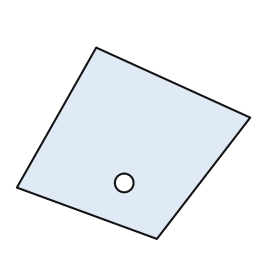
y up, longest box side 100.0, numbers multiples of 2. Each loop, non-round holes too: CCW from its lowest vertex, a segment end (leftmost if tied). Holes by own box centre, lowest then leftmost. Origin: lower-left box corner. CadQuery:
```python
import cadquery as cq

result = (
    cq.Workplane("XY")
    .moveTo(60.0, 0.0)
    .lineTo(100.0, 52.0)
    .lineTo(34.0, 82.0)
    .lineTo(0.0, 22.0)
    .close()
    .moveTo(46.0, 24.0)
    .circle(4.0)
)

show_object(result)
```